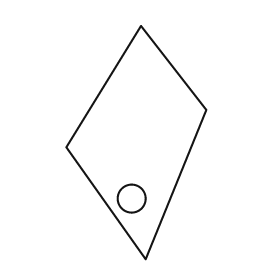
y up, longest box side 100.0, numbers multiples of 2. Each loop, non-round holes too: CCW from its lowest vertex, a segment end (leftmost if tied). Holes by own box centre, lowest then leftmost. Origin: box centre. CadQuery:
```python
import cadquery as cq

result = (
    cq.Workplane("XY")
    .moveTo(4.0, -50.0)
    .lineTo(30.0, 14.0)
    .lineTo(2.0, 50.0)
    .lineTo(-30.0, -2.0)
    .close()
    .moveTo(-2.0, -24.0)
    .circle(6.0)
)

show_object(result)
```